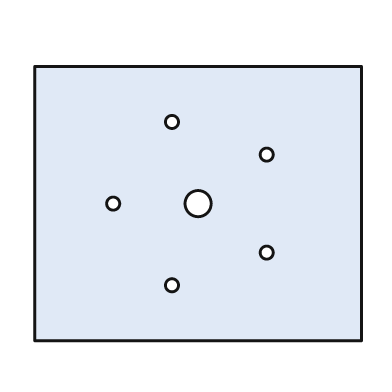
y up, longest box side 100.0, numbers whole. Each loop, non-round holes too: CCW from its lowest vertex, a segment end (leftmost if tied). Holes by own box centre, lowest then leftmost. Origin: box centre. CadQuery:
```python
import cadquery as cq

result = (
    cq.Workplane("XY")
    .moveTo(-50.0, -42.0)
    .lineTo(50.0, -42.0)
    .lineTo(50.0, 42.0)
    .lineTo(-50.0, 42.0)
    .close()
    .moveTo(-8.0, -25.0)
    .circle(2.0)
    .moveTo(21.0, -15.0)
    .circle(2.0)
    .moveTo(-26.0, 0.0)
    .circle(2.0)
    .moveTo(0.0, 0.0)
    .circle(4.0)
    .moveTo(21.0, 15.0)
    .circle(2.0)
    .moveTo(-8.0, 25.0)
    .circle(2.0)
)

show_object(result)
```